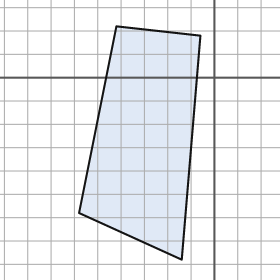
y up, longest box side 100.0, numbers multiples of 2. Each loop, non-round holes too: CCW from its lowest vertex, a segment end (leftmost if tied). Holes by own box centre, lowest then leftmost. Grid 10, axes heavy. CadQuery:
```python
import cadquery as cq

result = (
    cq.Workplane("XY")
    .moveTo(-14.0, -78.0)
    .lineTo(-6.0, 18.0)
    .lineTo(-42.0, 22.0)
    .lineTo(-58.0, -58.0)
    .close()
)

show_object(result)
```